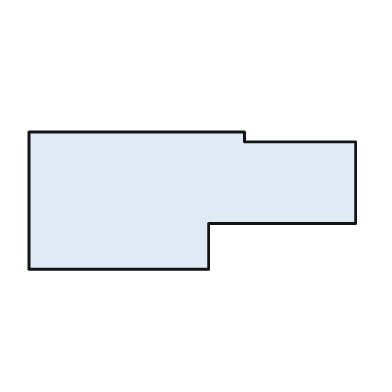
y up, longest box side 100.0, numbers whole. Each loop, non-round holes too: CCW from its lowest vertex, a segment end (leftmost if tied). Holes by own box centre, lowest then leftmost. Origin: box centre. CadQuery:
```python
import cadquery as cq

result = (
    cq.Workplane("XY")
    .moveTo(-50.0, -21.0)
    .lineTo(5.0, -21.0)
    .lineTo(5.0, -7.0)
    .lineTo(50.0, -7.0)
    .lineTo(50.0, 18.0)
    .lineTo(16.0, 18.0)
    .lineTo(16.0, 21.0)
    .lineTo(-50.0, 21.0)
    .close()
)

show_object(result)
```